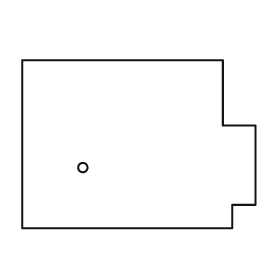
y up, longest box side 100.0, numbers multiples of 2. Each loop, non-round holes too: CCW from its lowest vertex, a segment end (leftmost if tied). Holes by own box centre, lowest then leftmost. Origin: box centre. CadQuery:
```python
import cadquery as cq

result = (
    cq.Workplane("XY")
    .moveTo(-50.0, -36.0)
    .lineTo(40.0, -36.0)
    .lineTo(40.0, -26.0)
    .lineTo(50.0, -26.0)
    .lineTo(50.0, 8.0)
    .lineTo(36.0, 8.0)
    .lineTo(36.0, 36.0)
    .lineTo(-50.0, 36.0)
    .close()
    .moveTo(-24.0, -10.0)
    .circle(2.0)
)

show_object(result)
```